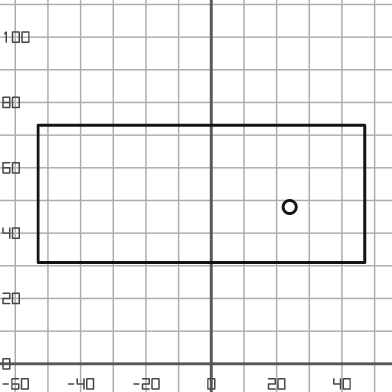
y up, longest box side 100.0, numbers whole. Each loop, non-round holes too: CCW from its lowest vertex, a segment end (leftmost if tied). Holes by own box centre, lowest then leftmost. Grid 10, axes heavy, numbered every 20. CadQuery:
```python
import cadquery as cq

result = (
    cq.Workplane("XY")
    .moveTo(-53.0, 31.0)
    .lineTo(47.0, 31.0)
    .lineTo(47.0, 73.0)
    .lineTo(-53.0, 73.0)
    .close()
    .moveTo(24.0, 48.0)
    .circle(2.0)
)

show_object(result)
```